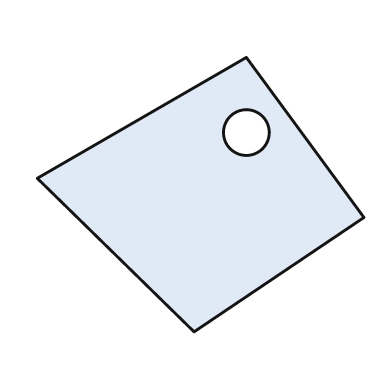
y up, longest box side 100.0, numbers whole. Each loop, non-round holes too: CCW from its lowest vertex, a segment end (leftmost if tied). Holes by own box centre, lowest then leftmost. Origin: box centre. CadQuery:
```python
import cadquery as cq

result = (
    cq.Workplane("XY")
    .moveTo(-2.0, -42.0)
    .lineTo(50.0, -7.0)
    .lineTo(14.0, 42.0)
    .lineTo(-50.0, 5.0)
    .close()
    .moveTo(14.0, 19.0)
    .circle(7.0)
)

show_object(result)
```